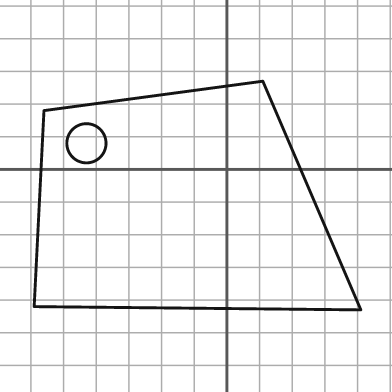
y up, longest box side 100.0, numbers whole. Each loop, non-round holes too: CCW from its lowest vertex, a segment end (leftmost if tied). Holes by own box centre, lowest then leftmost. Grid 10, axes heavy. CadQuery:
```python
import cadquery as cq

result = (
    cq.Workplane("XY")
    .moveTo(41.0, -43.0)
    .lineTo(11.0, 27.0)
    .lineTo(-56.0, 18.0)
    .lineTo(-59.0, -42.0)
    .close()
    .moveTo(-43.0, 8.0)
    .circle(6.0)
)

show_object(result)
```